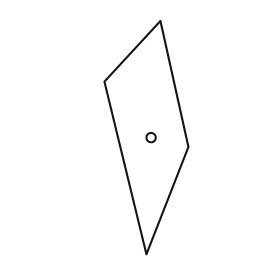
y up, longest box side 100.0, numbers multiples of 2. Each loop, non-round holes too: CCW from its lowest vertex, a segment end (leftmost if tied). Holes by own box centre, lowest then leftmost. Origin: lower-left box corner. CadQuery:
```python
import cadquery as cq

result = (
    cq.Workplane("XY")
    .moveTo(18.0, 0.0)
    .lineTo(36.0, 46.0)
    .lineTo(24.0, 100.0)
    .lineTo(0.0, 74.0)
    .close()
    .moveTo(20.0, 50.0)
    .circle(2.0)
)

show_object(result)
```